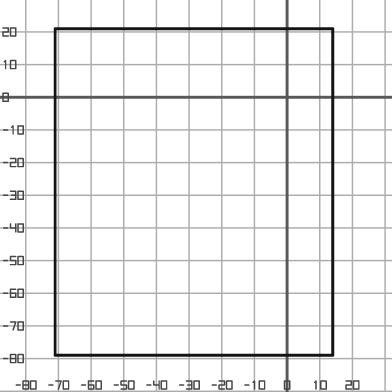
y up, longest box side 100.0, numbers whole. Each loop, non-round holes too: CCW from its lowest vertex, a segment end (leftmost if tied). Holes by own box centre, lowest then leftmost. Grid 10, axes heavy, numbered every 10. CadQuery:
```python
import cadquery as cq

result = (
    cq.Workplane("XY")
    .moveTo(-71.0, -79.0)
    .lineTo(14.0, -79.0)
    .lineTo(14.0, 21.0)
    .lineTo(-71.0, 21.0)
    .close()
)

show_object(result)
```